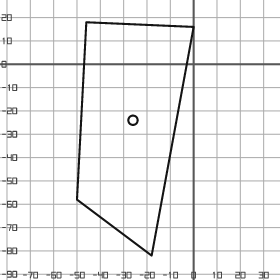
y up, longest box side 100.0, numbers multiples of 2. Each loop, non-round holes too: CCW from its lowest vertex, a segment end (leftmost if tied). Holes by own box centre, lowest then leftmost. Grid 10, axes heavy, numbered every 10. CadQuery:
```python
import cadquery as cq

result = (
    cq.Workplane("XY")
    .moveTo(-18.0, -82.0)
    .lineTo(0.0, 16.0)
    .lineTo(-46.0, 18.0)
    .lineTo(-50.0, -58.0)
    .close()
    .moveTo(-26.0, -24.0)
    .circle(2.0)
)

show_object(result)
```